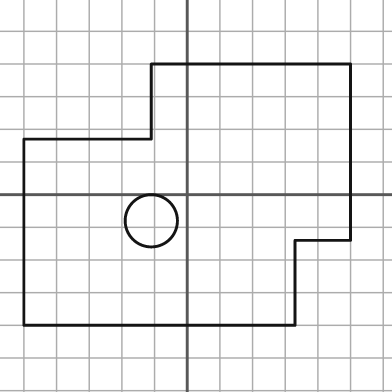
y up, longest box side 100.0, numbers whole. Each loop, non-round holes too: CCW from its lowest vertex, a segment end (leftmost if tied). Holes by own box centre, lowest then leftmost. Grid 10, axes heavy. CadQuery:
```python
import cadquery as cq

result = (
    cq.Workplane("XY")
    .moveTo(-50.0, -40.0)
    .lineTo(33.0, -40.0)
    .lineTo(33.0, -14.0)
    .lineTo(50.0, -14.0)
    .lineTo(50.0, 40.0)
    .lineTo(-11.0, 40.0)
    .lineTo(-11.0, 17.0)
    .lineTo(-50.0, 17.0)
    .close()
    .moveTo(-11.0, -8.0)
    .circle(8.0)
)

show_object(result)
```